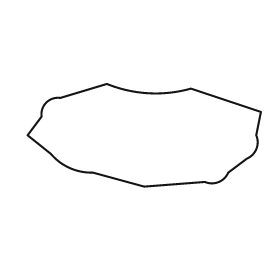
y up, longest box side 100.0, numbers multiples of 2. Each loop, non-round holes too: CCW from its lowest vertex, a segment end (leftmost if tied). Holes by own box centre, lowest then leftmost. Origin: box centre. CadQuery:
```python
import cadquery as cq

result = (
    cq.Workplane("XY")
    .moveTo(0.0, -22.0)
    .lineTo(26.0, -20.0)
    .threePointArc((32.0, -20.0), (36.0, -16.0))
    .lineTo(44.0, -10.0)
    .threePointArc((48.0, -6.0), (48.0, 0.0))
    .lineTo(50.0, 10.0)
    .lineTo(20.0, 20.0)
    .threePointArc((2.0, 18.0), (-16.0, 22.0))
    .lineTo(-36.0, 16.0)
    .threePointArc((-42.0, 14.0), (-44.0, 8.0))
    .lineTo(-50.0, 0.0)
    .lineTo(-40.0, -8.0)
    .threePointArc((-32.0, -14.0), (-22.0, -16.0))
    .close()
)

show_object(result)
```